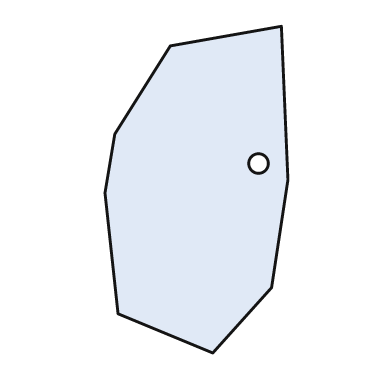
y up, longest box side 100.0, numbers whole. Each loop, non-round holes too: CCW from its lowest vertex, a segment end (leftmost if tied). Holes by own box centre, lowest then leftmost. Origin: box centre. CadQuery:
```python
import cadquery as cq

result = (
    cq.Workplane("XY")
    .moveTo(5.0, -50.0)
    .lineTo(23.0, -30.0)
    .lineTo(28.0, 3.0)
    .lineTo(26.0, 50.0)
    .lineTo(-8.0, 44.0)
    .lineTo(-25.0, 17.0)
    .lineTo(-28.0, -1.0)
    .lineTo(-24.0, -38.0)
    .close()
    .moveTo(19.0, 8.0)
    .circle(3.0)
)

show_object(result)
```